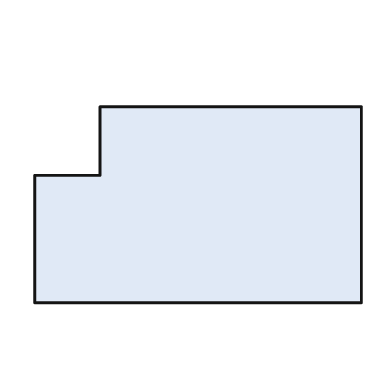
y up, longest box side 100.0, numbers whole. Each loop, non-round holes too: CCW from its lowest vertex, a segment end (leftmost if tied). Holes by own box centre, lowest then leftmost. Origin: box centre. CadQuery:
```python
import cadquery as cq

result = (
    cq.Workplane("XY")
    .moveTo(-50.0, -30.0)
    .lineTo(50.0, -30.0)
    .lineTo(50.0, 30.0)
    .lineTo(-30.0, 30.0)
    .lineTo(-30.0, 9.0)
    .lineTo(-50.0, 9.0)
    .close()
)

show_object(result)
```